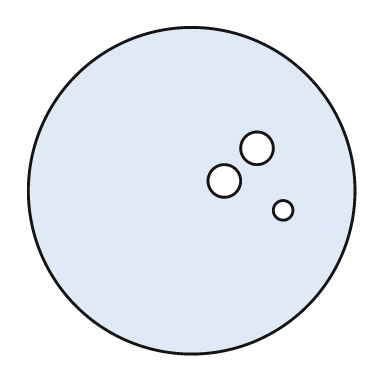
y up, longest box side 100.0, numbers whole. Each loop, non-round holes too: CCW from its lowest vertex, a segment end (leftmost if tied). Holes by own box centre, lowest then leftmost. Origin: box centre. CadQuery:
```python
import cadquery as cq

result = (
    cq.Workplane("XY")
    .moveTo(0.0, 0.0)
    .circle(50.0)
    .moveTo(28.0, -6.0)
    .circle(3.0)
    .moveTo(10.0, 3.0)
    .circle(5.0)
    .moveTo(20.0, 13.0)
    .circle(5.0)
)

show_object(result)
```